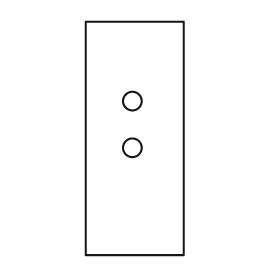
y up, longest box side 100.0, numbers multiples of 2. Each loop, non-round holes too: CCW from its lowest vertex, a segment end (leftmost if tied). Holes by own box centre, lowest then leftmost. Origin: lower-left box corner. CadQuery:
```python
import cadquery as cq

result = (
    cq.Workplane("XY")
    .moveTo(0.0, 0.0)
    .lineTo(42.0, 0.0)
    .lineTo(42.0, 100.0)
    .lineTo(0.0, 100.0)
    .close()
    .moveTo(20.0, 46.0)
    .circle(4.0)
    .moveTo(20.0, 66.0)
    .circle(4.0)
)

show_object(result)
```